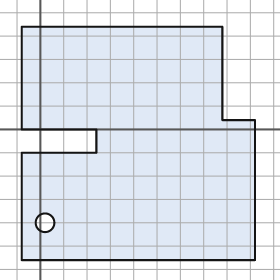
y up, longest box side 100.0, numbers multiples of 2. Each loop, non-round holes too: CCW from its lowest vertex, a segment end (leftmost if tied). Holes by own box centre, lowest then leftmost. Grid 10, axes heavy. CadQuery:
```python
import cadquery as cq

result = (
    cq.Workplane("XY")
    .moveTo(-8.0, -56.0)
    .lineTo(92.0, -56.0)
    .lineTo(92.0, 4.0)
    .lineTo(78.0, 4.0)
    .lineTo(78.0, 44.0)
    .lineTo(-8.0, 44.0)
    .lineTo(-8.0, 0.0)
    .lineTo(24.0, 0.0)
    .lineTo(24.0, -10.0)
    .lineTo(-8.0, -10.0)
    .close()
    .moveTo(2.0, -40.0)
    .circle(4.0)
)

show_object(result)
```